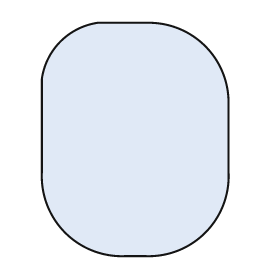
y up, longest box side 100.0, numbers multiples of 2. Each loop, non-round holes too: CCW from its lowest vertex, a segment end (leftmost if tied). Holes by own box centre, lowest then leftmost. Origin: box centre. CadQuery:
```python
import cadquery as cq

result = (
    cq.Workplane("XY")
    .moveTo(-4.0, -50.0)
    .lineTo(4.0, -50.0)
    .threePointArc((30.0, -40.0), (40.0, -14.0))
    .lineTo(40.0, 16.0)
    .threePointArc((30.0, 40.0), (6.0, 50.0))
    .lineTo(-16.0, 50.0)
    .threePointArc((-32.0, 42.0), (-40.0, 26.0))
    .lineTo(-40.0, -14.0)
    .threePointArc((-30.0, -40.0), (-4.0, -50.0))
    .close()
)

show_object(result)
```